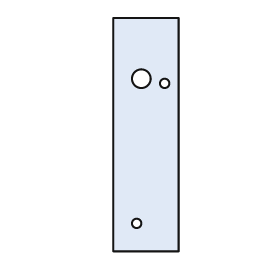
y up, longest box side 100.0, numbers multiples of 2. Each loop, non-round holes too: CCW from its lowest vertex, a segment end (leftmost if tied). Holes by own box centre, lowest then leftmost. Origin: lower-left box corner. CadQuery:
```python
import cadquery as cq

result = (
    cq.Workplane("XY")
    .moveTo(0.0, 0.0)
    .lineTo(28.0, 0.0)
    .lineTo(28.0, 100.0)
    .lineTo(0.0, 100.0)
    .close()
    .moveTo(10.0, 12.0)
    .circle(2.0)
    .moveTo(22.0, 72.0)
    .circle(2.0)
    .moveTo(12.0, 74.0)
    .circle(4.0)
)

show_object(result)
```